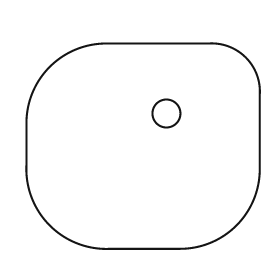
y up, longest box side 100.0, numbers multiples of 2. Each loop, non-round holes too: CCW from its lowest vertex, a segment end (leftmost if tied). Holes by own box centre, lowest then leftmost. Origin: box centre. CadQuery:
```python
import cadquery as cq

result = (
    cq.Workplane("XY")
    .moveTo(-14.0, -44.0)
    .lineTo(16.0, -44.0)
    .threePointArc((40.0, -34.0), (50.0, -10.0))
    .lineTo(50.0, 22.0)
    .threePointArc((44.0, 38.0), (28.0, 44.0))
    .lineTo(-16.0, 44.0)
    .threePointArc((-40.0, 34.0), (-50.0, 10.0))
    .lineTo(-50.0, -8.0)
    .threePointArc((-40.0, -34.0), (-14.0, -44.0))
    .close()
    .moveTo(10.0, 14.0)
    .circle(6.0)
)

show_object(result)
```